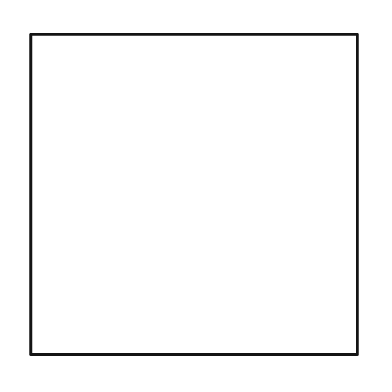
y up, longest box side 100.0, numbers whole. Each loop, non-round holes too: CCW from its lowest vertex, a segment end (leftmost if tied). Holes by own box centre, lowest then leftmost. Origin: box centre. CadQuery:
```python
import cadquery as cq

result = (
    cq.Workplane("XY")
    .moveTo(-50.0, -49.0)
    .lineTo(50.0, -49.0)
    .lineTo(50.0, 49.0)
    .lineTo(-50.0, 49.0)
    .close()
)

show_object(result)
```